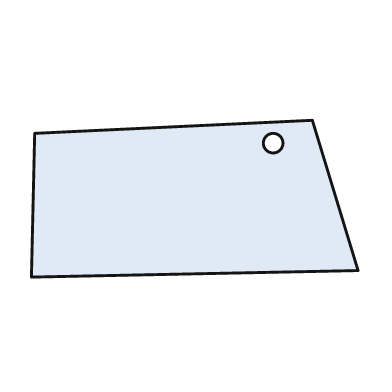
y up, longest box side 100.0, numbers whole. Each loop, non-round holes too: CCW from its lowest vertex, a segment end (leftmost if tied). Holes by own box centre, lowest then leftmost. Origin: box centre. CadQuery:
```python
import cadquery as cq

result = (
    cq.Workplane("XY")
    .moveTo(-50.0, -24.0)
    .lineTo(50.0, -22.0)
    .lineTo(36.0, 24.0)
    .lineTo(-49.0, 20.0)
    .close()
    .moveTo(24.0, 17.0)
    .circle(3.0)
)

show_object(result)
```